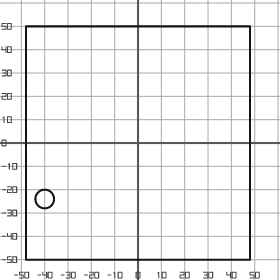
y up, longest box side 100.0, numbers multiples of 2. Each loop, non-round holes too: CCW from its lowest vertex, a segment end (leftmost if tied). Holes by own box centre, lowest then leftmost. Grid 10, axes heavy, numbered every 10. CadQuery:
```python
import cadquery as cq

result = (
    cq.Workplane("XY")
    .moveTo(-48.0, -50.0)
    .lineTo(48.0, -50.0)
    .lineTo(48.0, 50.0)
    .lineTo(-48.0, 50.0)
    .close()
    .moveTo(-40.0, -24.0)
    .circle(4.0)
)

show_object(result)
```